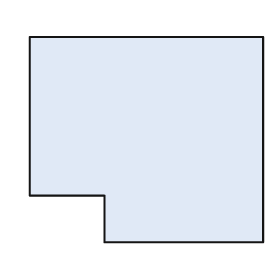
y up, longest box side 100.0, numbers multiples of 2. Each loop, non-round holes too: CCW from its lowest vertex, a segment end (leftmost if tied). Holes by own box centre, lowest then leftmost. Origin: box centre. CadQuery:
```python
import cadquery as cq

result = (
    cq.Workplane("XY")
    .moveTo(-18.0, -44.0)
    .lineTo(50.0, -44.0)
    .lineTo(50.0, 44.0)
    .lineTo(-50.0, 44.0)
    .lineTo(-50.0, -24.0)
    .lineTo(-18.0, -24.0)
    .close()
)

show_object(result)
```